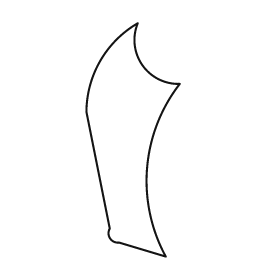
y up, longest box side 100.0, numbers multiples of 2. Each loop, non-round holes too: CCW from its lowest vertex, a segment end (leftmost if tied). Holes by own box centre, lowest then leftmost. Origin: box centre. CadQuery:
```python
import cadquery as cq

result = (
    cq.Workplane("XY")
    .moveTo(14.0, -50.0)
    .threePointArc((6.0, -12.0), (20.0, 24.0))
    .threePointArc((4.0, 32.0), (2.0, 50.0))
    .threePointArc((-14.0, 34.0), (-20.0, 12.0))
    .lineTo(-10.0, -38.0)
    .threePointArc((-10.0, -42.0), (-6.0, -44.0))
    .close()
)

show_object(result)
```